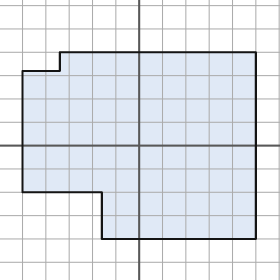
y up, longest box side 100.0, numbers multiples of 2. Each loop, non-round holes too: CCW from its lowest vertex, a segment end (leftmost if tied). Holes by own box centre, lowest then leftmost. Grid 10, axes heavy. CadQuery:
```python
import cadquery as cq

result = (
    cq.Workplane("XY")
    .moveTo(-16.0, -40.0)
    .lineTo(50.0, -40.0)
    .lineTo(50.0, 40.0)
    .lineTo(-34.0, 40.0)
    .lineTo(-34.0, 32.0)
    .lineTo(-50.0, 32.0)
    .lineTo(-50.0, -20.0)
    .lineTo(-16.0, -20.0)
    .close()
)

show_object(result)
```